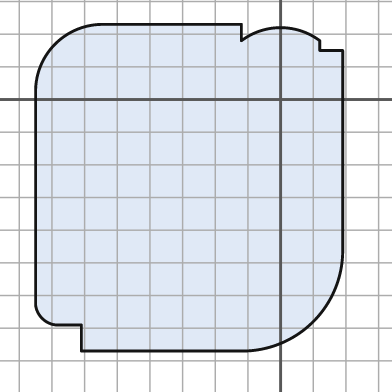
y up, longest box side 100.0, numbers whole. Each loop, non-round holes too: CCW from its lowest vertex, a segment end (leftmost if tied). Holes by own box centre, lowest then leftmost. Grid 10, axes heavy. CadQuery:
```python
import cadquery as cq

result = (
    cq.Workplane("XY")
    .moveTo(-61.0, -77.0)
    .lineTo(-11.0, -77.0)
    .threePointArc((10.0, -68.0), (19.0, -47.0))
    .lineTo(19.0, 15.0)
    .lineTo(12.0, 15.0)
    .lineTo(12.0, 18.0)
    .threePointArc((0.0, 22.0), (-12.0, 18.0))
    .lineTo(-12.0, 23.0)
    .lineTo(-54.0, 23.0)
    .threePointArc((-69.0, 17.0), (-75.0, 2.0))
    .lineTo(-75.0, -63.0)
    .threePointArc((-73.0, -67.0), (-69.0, -69.0))
    .lineTo(-61.0, -69.0)
    .close()
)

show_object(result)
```